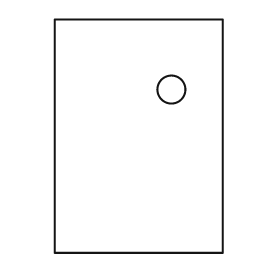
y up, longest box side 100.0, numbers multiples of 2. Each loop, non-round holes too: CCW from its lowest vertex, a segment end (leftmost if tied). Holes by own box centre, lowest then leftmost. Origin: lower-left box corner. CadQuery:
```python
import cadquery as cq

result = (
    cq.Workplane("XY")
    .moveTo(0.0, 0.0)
    .lineTo(72.0, 0.0)
    .lineTo(72.0, 100.0)
    .lineTo(0.0, 100.0)
    .close()
    .moveTo(50.0, 70.0)
    .circle(6.0)
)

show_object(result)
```